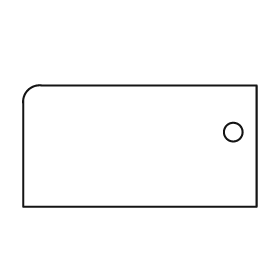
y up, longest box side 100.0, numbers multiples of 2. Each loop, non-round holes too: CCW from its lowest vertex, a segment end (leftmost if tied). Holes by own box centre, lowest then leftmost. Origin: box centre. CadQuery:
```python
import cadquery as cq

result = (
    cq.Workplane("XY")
    .moveTo(-50.0, -26.0)
    .lineTo(50.0, -26.0)
    .lineTo(50.0, 26.0)
    .lineTo(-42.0, 26.0)
    .threePointArc((-48.0, 24.0), (-50.0, 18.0))
    .close()
    .moveTo(40.0, 6.0)
    .circle(4.0)
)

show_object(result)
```